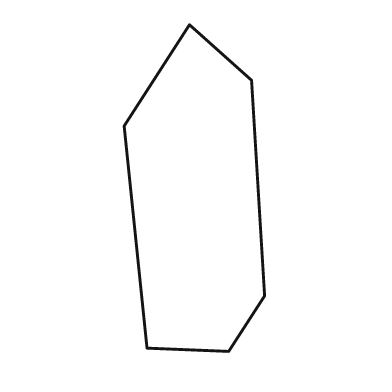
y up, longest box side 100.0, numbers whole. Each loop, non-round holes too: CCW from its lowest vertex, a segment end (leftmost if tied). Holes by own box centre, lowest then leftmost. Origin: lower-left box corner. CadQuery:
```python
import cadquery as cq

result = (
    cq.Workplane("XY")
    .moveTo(32.0, 0.0)
    .lineTo(43.0, 17.0)
    .lineTo(39.0, 83.0)
    .lineTo(20.0, 100.0)
    .lineTo(0.0, 69.0)
    .lineTo(7.0, 1.0)
    .close()
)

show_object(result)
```